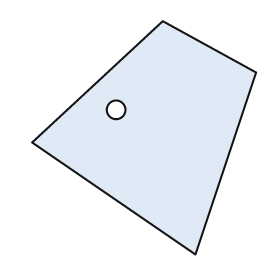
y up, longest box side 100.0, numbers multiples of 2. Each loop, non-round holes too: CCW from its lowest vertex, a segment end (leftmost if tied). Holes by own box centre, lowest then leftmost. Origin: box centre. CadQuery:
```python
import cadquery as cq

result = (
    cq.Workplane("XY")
    .moveTo(22.0, -50.0)
    .lineTo(48.0, 28.0)
    .lineTo(8.0, 50.0)
    .lineTo(-48.0, -2.0)
    .close()
    .moveTo(-12.0, 12.0)
    .circle(4.0)
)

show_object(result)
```